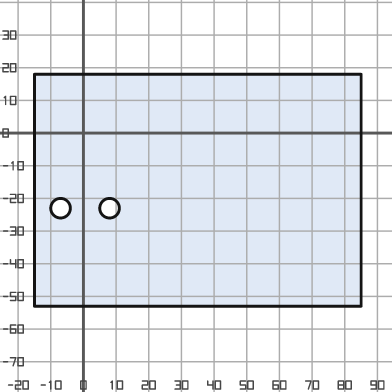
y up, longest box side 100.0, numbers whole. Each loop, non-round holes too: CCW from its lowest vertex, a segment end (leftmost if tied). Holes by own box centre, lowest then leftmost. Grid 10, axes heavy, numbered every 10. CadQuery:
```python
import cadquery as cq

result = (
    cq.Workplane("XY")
    .moveTo(-15.0, -53.0)
    .lineTo(85.0, -53.0)
    .lineTo(85.0, 18.0)
    .lineTo(-15.0, 18.0)
    .close()
    .moveTo(-7.0, -23.0)
    .circle(3.0)
    .moveTo(8.0, -23.0)
    .circle(3.0)
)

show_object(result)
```